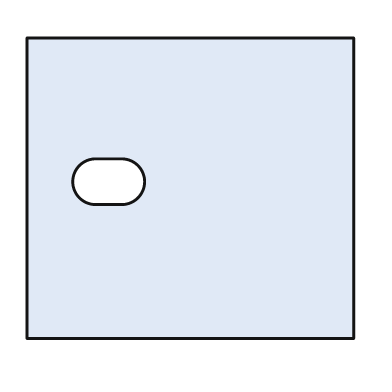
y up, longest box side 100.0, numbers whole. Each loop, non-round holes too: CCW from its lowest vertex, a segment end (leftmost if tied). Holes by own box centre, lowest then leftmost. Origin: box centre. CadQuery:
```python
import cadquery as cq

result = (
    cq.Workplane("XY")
    .moveTo(-50.0, -46.0)
    .lineTo(50.0, -46.0)
    .lineTo(50.0, 46.0)
    .lineTo(-50.0, 46.0)
    .close()
    .moveTo(-29.0, -5.0)
    .lineTo(-21.0, -5.0)
    .threePointArc((-14.0, 2.0), (-21.0, 9.0))
    .lineTo(-29.0, 9.0)
    .threePointArc((-36.0, 2.0), (-29.0, -5.0))
    .close()
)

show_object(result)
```